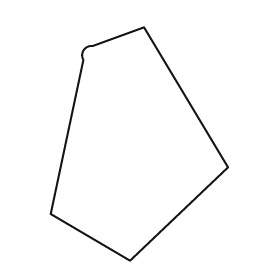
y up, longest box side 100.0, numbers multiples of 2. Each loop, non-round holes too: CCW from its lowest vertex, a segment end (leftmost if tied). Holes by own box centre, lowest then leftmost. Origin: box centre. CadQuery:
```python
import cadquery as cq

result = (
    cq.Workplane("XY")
    .moveTo(-4.0, -50.0)
    .lineTo(38.0, -10.0)
    .lineTo(2.0, 50.0)
    .lineTo(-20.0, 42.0)
    .threePointArc((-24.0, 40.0), (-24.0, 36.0))
    .lineTo(-38.0, -30.0)
    .close()
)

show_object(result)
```